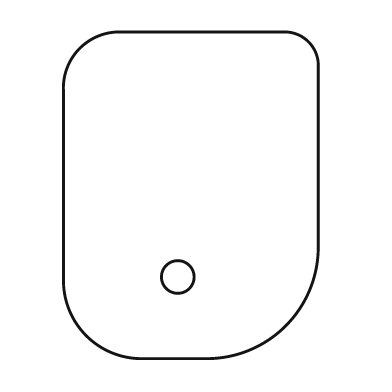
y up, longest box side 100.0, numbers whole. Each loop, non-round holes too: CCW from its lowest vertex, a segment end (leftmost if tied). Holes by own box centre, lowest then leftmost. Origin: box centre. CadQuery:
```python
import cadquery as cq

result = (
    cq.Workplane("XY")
    .moveTo(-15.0, -50.0)
    .lineTo(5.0, -50.0)
    .threePointArc((29.0, -40.0), (39.0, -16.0))
    .lineTo(39.0, 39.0)
    .threePointArc((36.0, 47.0), (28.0, 50.0))
    .lineTo(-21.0, 50.0)
    .threePointArc((-34.0, 45.0), (-39.0, 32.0))
    .lineTo(-39.0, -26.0)
    .threePointArc((-32.0, -43.0), (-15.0, -50.0))
    .close()
    .moveTo(-4.0, -25.0)
    .circle(5.0)
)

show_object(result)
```